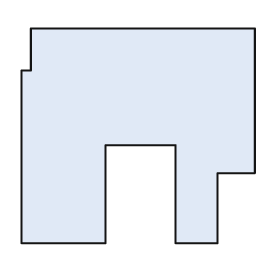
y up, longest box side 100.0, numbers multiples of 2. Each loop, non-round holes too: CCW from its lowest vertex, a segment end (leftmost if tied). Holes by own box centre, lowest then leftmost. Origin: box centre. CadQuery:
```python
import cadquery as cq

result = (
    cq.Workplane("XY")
    .moveTo(-50.0, -46.0)
    .lineTo(-14.0, -46.0)
    .lineTo(-14.0, -4.0)
    .lineTo(16.0, -4.0)
    .lineTo(16.0, -46.0)
    .lineTo(34.0, -46.0)
    .lineTo(34.0, -16.0)
    .lineTo(50.0, -16.0)
    .lineTo(50.0, 46.0)
    .lineTo(-46.0, 46.0)
    .lineTo(-46.0, 28.0)
    .lineTo(-50.0, 28.0)
    .close()
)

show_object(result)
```